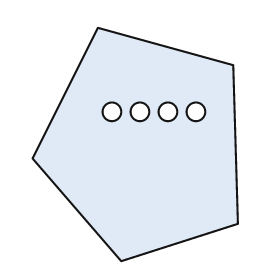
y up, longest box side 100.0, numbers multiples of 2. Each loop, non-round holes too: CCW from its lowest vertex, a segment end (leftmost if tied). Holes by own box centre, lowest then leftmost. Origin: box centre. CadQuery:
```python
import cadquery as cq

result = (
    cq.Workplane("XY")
    .moveTo(-6.0, -50.0)
    .lineTo(44.0, -34.0)
    .lineTo(42.0, 34.0)
    .lineTo(-16.0, 50.0)
    .lineTo(-44.0, -6.0)
    .close()
    .moveTo(-10.0, 14.0)
    .circle(4.0)
    .moveTo(2.0, 14.0)
    .circle(4.0)
    .moveTo(14.0, 14.0)
    .circle(4.0)
    .moveTo(26.0, 14.0)
    .circle(4.0)
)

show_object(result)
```